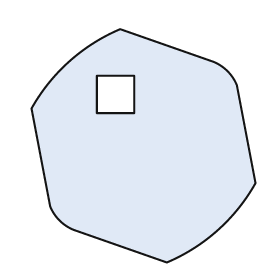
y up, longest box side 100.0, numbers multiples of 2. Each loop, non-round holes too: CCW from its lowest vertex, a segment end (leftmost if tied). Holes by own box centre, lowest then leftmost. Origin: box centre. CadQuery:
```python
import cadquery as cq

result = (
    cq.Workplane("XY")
    .moveTo(10.0, -50.0)
    .threePointArc((32.0, -36.0), (48.0, -16.0))
    .lineTo(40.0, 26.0)
    .threePointArc((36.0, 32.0), (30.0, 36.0))
    .lineTo(-10.0, 50.0)
    .threePointArc((-32.0, 36.0), (-48.0, 16.0))
    .lineTo(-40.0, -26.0)
    .threePointArc((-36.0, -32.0), (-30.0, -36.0))
    .close()
    .moveTo(-20.0, 14.0)
    .lineTo(-4.0, 14.0)
    .lineTo(-4.0, 30.0)
    .lineTo(-20.0, 30.0)
    .close()
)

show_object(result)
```